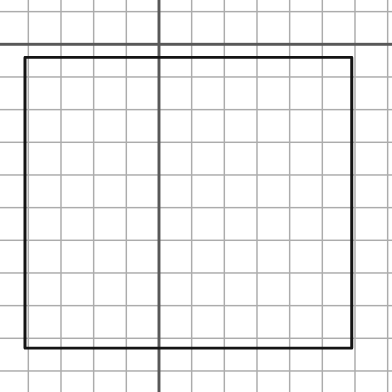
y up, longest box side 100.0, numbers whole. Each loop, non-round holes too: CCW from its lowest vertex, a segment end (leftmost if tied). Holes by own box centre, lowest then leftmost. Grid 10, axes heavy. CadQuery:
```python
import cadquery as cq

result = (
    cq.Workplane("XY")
    .moveTo(-41.0, -93.0)
    .lineTo(59.0, -93.0)
    .lineTo(59.0, -4.0)
    .lineTo(-41.0, -4.0)
    .close()
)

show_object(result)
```